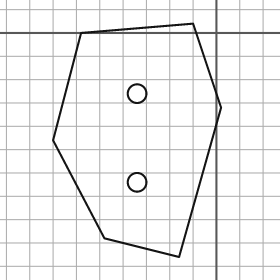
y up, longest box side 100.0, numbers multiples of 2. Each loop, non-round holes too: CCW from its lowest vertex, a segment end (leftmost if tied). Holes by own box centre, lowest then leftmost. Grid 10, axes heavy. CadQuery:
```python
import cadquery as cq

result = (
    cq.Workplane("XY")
    .moveTo(-16.0, -96.0)
    .lineTo(2.0, -32.0)
    .lineTo(-10.0, 4.0)
    .lineTo(-58.0, 0.0)
    .lineTo(-70.0, -46.0)
    .lineTo(-48.0, -88.0)
    .close()
    .moveTo(-34.0, -64.0)
    .circle(4.0)
    .moveTo(-34.0, -26.0)
    .circle(4.0)
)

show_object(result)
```